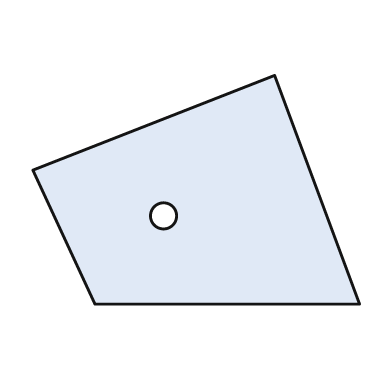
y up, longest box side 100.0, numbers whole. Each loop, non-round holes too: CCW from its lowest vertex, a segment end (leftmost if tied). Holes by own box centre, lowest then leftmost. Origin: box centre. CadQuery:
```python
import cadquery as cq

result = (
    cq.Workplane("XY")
    .moveTo(-31.0, -35.0)
    .lineTo(50.0, -35.0)
    .lineTo(24.0, 35.0)
    .lineTo(-50.0, 6.0)
    .close()
    .moveTo(-10.0, -8.0)
    .circle(4.0)
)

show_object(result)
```